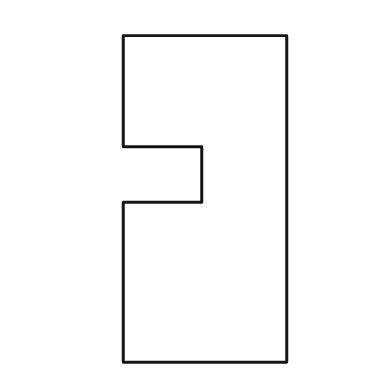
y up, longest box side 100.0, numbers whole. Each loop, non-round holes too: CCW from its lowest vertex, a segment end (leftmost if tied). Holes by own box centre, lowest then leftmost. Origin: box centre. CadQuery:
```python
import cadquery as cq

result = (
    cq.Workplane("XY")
    .moveTo(-25.0, -50.0)
    .lineTo(25.0, -50.0)
    .lineTo(25.0, 50.0)
    .lineTo(-25.0, 50.0)
    .lineTo(-25.0, 16.0)
    .lineTo(-1.0, 16.0)
    .lineTo(-1.0, -1.0)
    .lineTo(-25.0, -1.0)
    .close()
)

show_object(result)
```